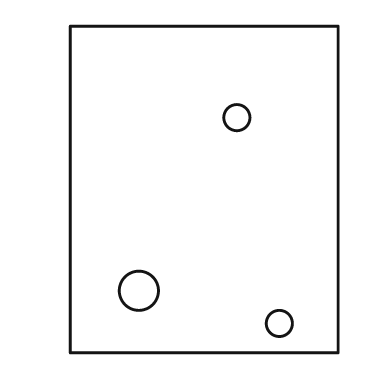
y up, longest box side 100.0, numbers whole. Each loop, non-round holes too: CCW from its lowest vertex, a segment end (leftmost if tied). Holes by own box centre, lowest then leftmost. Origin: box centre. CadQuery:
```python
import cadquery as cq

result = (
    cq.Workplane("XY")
    .moveTo(-41.0, -50.0)
    .lineTo(41.0, -50.0)
    .lineTo(41.0, 50.0)
    .lineTo(-41.0, 50.0)
    .close()
    .moveTo(23.0, -41.0)
    .circle(4.0)
    .moveTo(-20.0, -31.0)
    .circle(6.0)
    .moveTo(10.0, 22.0)
    .circle(4.0)
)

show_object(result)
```